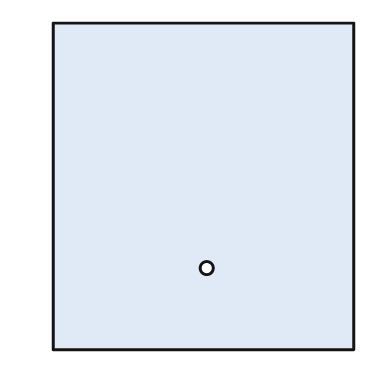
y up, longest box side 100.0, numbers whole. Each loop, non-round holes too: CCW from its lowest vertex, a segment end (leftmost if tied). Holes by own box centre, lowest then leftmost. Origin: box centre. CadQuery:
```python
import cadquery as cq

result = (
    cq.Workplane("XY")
    .moveTo(-46.0, -50.0)
    .lineTo(46.0, -50.0)
    .lineTo(46.0, 50.0)
    .lineTo(-46.0, 50.0)
    .close()
    .moveTo(1.0, -25.0)
    .circle(2.0)
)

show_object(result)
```